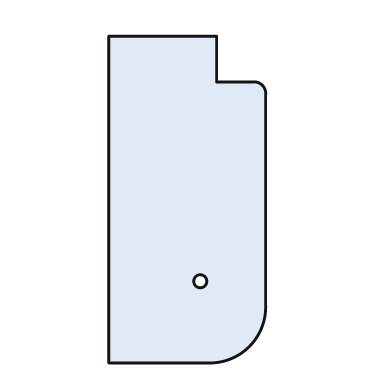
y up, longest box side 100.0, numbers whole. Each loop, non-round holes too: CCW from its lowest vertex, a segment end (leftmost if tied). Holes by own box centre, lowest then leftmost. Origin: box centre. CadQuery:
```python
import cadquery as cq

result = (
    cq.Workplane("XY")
    .moveTo(-24.0, -50.0)
    .lineTo(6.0, -50.0)
    .threePointArc((19.0, -45.0), (24.0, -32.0))
    .lineTo(24.0, 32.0)
    .threePointArc((23.0, 35.0), (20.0, 36.0))
    .lineTo(9.0, 36.0)
    .lineTo(9.0, 50.0)
    .lineTo(-24.0, 50.0)
    .close()
    .moveTo(4.0, -25.0)
    .circle(2.0)
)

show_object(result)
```